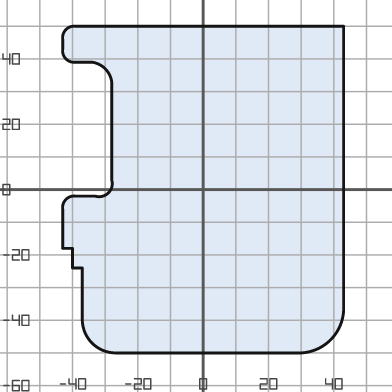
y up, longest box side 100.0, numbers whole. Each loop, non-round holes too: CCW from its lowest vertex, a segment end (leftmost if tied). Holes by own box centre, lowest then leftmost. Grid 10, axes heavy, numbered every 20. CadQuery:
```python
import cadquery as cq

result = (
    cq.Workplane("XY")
    .moveTo(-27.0, -50.0)
    .lineTo(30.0, -50.0)
    .threePointArc((39.0, -46.0), (43.0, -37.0))
    .lineTo(43.0, 50.0)
    .lineTo(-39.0, 50.0)
    .threePointArc((-42.0, 49.0), (-43.0, 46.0))
    .lineTo(-43.0, 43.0)
    .threePointArc((-42.0, 40.0), (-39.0, 39.0))
    .lineTo(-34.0, 39.0)
    .threePointArc((-30.0, 37.0), (-28.0, 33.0))
    .lineTo(-28.0, 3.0)
    .threePointArc((-29.0, -1.0), (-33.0, -2.0))
    .lineTo(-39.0, -2.0)
    .threePointArc((-42.0, -3.0), (-43.0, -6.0))
    .lineTo(-43.0, -18.0)
    .lineTo(-40.0, -18.0)
    .lineTo(-40.0, -24.0)
    .lineTo(-37.0, -24.0)
    .lineTo(-37.0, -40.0)
    .threePointArc((-34.0, -47.0), (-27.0, -50.0))
    .close()
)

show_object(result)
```